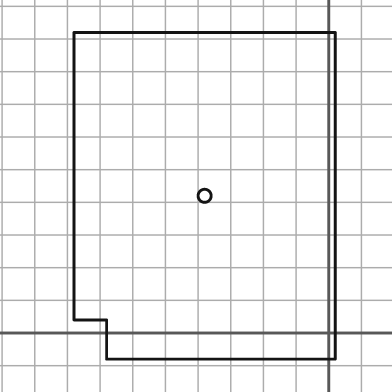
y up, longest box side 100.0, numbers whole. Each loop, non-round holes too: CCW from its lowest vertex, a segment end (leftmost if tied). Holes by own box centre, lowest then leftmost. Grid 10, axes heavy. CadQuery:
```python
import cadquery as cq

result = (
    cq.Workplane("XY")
    .moveTo(-68.0, -8.0)
    .lineTo(2.0, -8.0)
    .lineTo(2.0, 92.0)
    .lineTo(-78.0, 92.0)
    .lineTo(-78.0, 4.0)
    .lineTo(-68.0, 4.0)
    .close()
    .moveTo(-38.0, 42.0)
    .circle(2.0)
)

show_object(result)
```